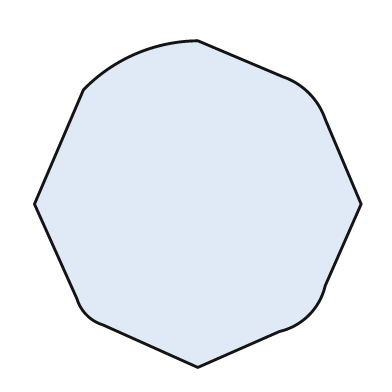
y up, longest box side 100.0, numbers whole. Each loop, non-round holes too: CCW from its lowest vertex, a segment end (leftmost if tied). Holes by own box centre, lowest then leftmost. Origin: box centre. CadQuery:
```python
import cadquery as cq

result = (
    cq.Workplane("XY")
    .moveTo(0.0, -50.0)
    .lineTo(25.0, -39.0)
    .threePointArc((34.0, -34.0), (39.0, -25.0))
    .lineTo(50.0, 0.0)
    .lineTo(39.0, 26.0)
    .threePointArc((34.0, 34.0), (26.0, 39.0))
    .lineTo(0.0, 50.0)
    .threePointArc((-19.0, 46.0), (-35.0, 35.0))
    .lineTo(-50.0, 0.0)
    .lineTo(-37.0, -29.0)
    .threePointArc((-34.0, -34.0), (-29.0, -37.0))
    .close()
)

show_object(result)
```